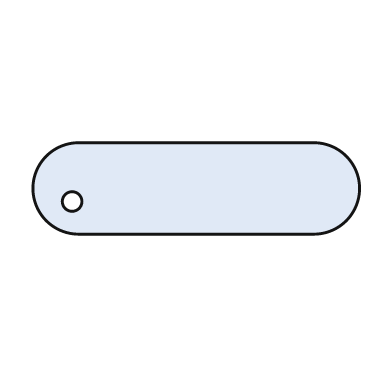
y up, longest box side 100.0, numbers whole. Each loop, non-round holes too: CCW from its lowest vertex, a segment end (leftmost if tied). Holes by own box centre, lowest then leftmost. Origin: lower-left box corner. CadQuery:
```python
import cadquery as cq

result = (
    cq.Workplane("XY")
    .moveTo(14.0, 0.0)
    .lineTo(86.0, 0.0)
    .threePointArc((100.0, 14.0), (86.0, 28.0))
    .lineTo(14.0, 28.0)
    .threePointArc((0.0, 14.0), (14.0, 0.0))
    .close()
    .moveTo(12.0, 10.0)
    .circle(3.0)
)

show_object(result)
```